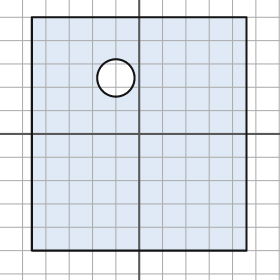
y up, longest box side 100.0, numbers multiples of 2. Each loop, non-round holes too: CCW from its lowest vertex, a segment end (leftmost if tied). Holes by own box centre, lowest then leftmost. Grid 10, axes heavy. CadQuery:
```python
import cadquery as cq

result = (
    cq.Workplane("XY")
    .moveTo(-46.0, -50.0)
    .lineTo(46.0, -50.0)
    .lineTo(46.0, 50.0)
    .lineTo(-46.0, 50.0)
    .close()
    .moveTo(-10.0, 24.0)
    .circle(8.0)
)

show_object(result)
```